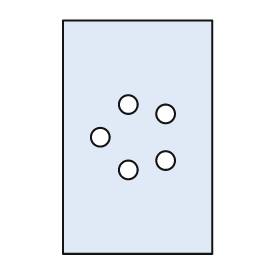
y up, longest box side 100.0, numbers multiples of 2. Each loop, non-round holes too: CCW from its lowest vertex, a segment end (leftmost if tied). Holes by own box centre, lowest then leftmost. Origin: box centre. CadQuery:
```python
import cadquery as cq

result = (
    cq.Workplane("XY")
    .moveTo(-32.0, -50.0)
    .lineTo(32.0, -50.0)
    .lineTo(32.0, 50.0)
    .lineTo(-32.0, 50.0)
    .close()
    .moveTo(-4.0, -14.0)
    .circle(4.0)
    .moveTo(12.0, -10.0)
    .circle(4.0)
    .moveTo(-16.0, 0.0)
    .circle(4.0)
    .moveTo(12.0, 10.0)
    .circle(4.0)
    .moveTo(-4.0, 14.0)
    .circle(4.0)
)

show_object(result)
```